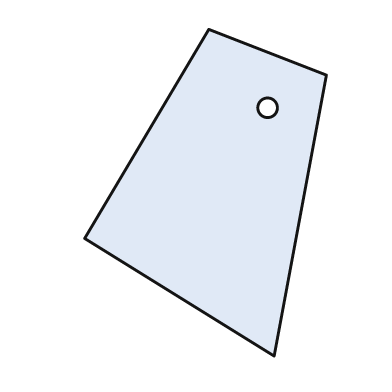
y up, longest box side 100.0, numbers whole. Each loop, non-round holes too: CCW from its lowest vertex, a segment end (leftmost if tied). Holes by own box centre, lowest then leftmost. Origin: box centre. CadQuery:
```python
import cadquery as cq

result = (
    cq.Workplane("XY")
    .moveTo(21.0, -50.0)
    .lineTo(37.0, 36.0)
    .lineTo(1.0, 50.0)
    .lineTo(-37.0, -14.0)
    .close()
    .moveTo(19.0, 26.0)
    .circle(3.0)
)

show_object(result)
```